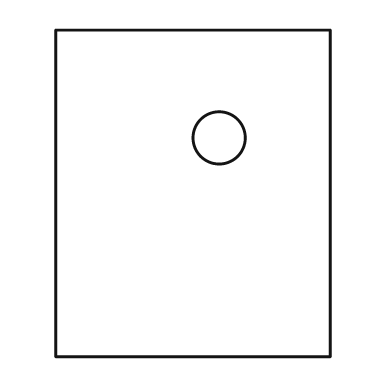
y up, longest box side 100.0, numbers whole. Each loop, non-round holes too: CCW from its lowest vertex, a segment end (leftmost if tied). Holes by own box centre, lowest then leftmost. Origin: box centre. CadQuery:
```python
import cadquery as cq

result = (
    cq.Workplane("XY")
    .moveTo(-42.0, -50.0)
    .lineTo(42.0, -50.0)
    .lineTo(42.0, 50.0)
    .lineTo(-42.0, 50.0)
    .close()
    .moveTo(8.0, 17.0)
    .circle(8.0)
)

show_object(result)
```